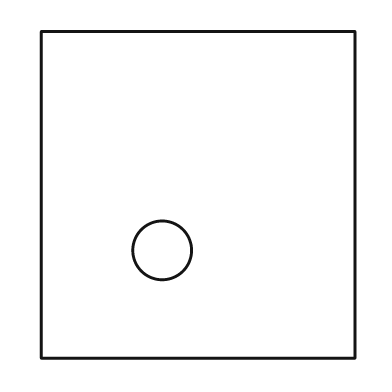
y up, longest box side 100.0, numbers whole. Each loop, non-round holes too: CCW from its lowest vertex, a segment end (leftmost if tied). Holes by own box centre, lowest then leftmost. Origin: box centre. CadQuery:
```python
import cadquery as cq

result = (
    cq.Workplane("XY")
    .moveTo(-48.0, -50.0)
    .lineTo(48.0, -50.0)
    .lineTo(48.0, 50.0)
    .lineTo(-48.0, 50.0)
    .close()
    .moveTo(-11.0, -17.0)
    .circle(9.0)
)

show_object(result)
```